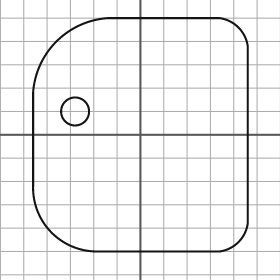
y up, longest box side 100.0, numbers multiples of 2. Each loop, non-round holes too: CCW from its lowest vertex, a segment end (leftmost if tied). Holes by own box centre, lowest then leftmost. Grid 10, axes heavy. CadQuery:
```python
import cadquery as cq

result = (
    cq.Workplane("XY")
    .moveTo(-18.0, -50.0)
    .lineTo(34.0, -50.0)
    .threePointArc((42.0, -46.0), (46.0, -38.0))
    .lineTo(46.0, 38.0)
    .threePointArc((42.0, 46.0), (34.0, 50.0))
    .lineTo(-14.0, 50.0)
    .threePointArc((-36.0, 40.0), (-46.0, 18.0))
    .lineTo(-46.0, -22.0)
    .threePointArc((-38.0, -42.0), (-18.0, -50.0))
    .close()
    .moveTo(-28.0, 10.0)
    .circle(6.0)
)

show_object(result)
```